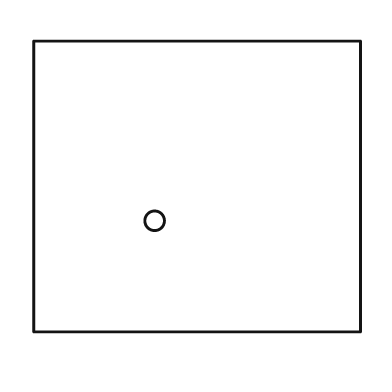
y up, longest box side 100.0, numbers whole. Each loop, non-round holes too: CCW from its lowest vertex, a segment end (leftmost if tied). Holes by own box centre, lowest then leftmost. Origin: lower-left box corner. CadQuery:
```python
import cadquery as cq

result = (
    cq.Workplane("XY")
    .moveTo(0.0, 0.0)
    .lineTo(100.0, 0.0)
    .lineTo(100.0, 89.0)
    .lineTo(0.0, 89.0)
    .close()
    .moveTo(37.0, 34.0)
    .circle(3.0)
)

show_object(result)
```